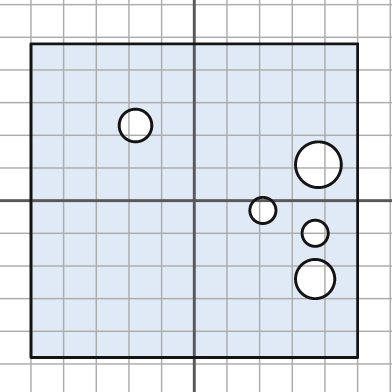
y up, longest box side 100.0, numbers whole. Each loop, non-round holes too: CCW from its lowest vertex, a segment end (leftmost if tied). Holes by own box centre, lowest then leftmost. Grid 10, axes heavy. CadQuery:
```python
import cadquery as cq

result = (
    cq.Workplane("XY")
    .moveTo(-50.0, -48.0)
    .lineTo(50.0, -48.0)
    .lineTo(50.0, 48.0)
    .lineTo(-50.0, 48.0)
    .close()
    .moveTo(37.0, -24.0)
    .circle(6.0)
    .moveTo(37.0, -10.0)
    .circle(4.0)
    .moveTo(21.0, -3.0)
    .circle(4.0)
    .moveTo(38.0, 11.0)
    .circle(7.0)
    .moveTo(-18.0, 23.0)
    .circle(5.0)
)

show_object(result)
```